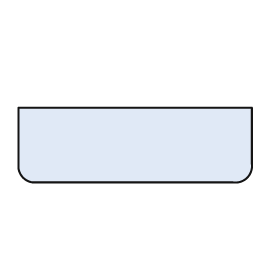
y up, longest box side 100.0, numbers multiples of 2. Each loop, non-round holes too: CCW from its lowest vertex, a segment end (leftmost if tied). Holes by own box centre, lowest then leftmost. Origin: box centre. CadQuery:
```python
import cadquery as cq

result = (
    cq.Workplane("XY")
    .moveTo(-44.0, -16.0)
    .lineTo(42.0, -16.0)
    .threePointArc((48.0, -14.0), (50.0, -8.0))
    .lineTo(50.0, 16.0)
    .lineTo(-50.0, 16.0)
    .lineTo(-50.0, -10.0)
    .threePointArc((-48.0, -14.0), (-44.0, -16.0))
    .close()
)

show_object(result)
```